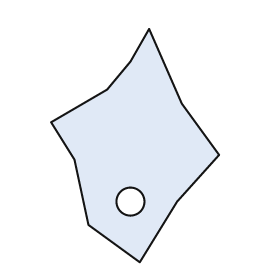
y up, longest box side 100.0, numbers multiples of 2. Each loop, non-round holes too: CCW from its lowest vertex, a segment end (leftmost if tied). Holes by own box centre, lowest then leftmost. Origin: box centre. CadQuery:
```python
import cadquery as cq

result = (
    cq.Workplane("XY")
    .moveTo(2.0, -50.0)
    .lineTo(18.0, -24.0)
    .lineTo(36.0, -4.0)
    .lineTo(20.0, 18.0)
    .lineTo(6.0, 50.0)
    .lineTo(-2.0, 36.0)
    .lineTo(-12.0, 24.0)
    .lineTo(-36.0, 10.0)
    .lineTo(-26.0, -6.0)
    .lineTo(-20.0, -34.0)
    .close()
    .moveTo(-2.0, -24.0)
    .circle(6.0)
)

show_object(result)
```